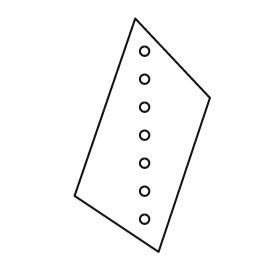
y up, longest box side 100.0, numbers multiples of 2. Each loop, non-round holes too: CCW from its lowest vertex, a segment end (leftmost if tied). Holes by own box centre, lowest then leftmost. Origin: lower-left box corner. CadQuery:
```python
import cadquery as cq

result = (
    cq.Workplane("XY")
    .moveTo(36.0, 0.0)
    .lineTo(58.0, 66.0)
    .lineTo(26.0, 100.0)
    .lineTo(0.0, 24.0)
    .close()
    .moveTo(30.0, 14.0)
    .circle(2.0)
    .moveTo(30.0, 26.0)
    .circle(2.0)
    .moveTo(30.0, 38.0)
    .circle(2.0)
    .moveTo(30.0, 50.0)
    .circle(2.0)
    .moveTo(30.0, 62.0)
    .circle(2.0)
    .moveTo(30.0, 74.0)
    .circle(2.0)
    .moveTo(30.0, 86.0)
    .circle(2.0)
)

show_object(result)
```